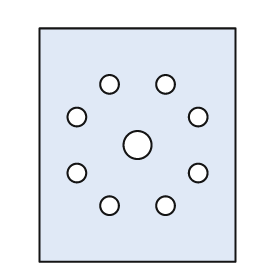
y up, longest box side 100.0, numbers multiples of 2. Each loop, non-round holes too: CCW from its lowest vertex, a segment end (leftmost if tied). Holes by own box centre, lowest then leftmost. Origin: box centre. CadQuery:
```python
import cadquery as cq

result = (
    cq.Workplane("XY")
    .moveTo(-42.0, -50.0)
    .lineTo(42.0, -50.0)
    .lineTo(42.0, 50.0)
    .lineTo(-42.0, 50.0)
    .close()
    .moveTo(-12.0, -26.0)
    .circle(4.0)
    .moveTo(12.0, -26.0)
    .circle(4.0)
    .moveTo(-26.0, -12.0)
    .circle(4.0)
    .moveTo(26.0, -12.0)
    .circle(4.0)
    .moveTo(0.0, 0.0)
    .circle(6.0)
    .moveTo(-26.0, 12.0)
    .circle(4.0)
    .moveTo(26.0, 12.0)
    .circle(4.0)
    .moveTo(-12.0, 26.0)
    .circle(4.0)
    .moveTo(12.0, 26.0)
    .circle(4.0)
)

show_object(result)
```